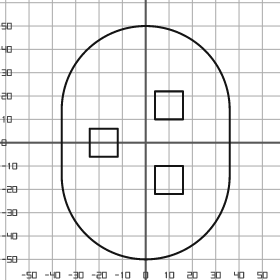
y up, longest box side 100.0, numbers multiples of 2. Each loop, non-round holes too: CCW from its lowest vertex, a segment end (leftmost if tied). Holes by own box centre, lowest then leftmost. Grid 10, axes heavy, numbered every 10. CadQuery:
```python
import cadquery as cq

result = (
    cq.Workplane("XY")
    .moveTo(-36.0, -14.0)
    .threePointArc((0.0, -50.0), (36.0, -14.0))
    .lineTo(36.0, 14.0)
    .threePointArc((0.0, 50.0), (-36.0, 14.0))
    .close()
    .moveTo(4.0, -22.0)
    .lineTo(16.0, -22.0)
    .lineTo(16.0, -10.0)
    .lineTo(4.0, -10.0)
    .close()
    .moveTo(-24.0, -6.0)
    .lineTo(-12.0, -6.0)
    .lineTo(-12.0, 6.0)
    .lineTo(-24.0, 6.0)
    .close()
    .moveTo(4.0, 10.0)
    .lineTo(16.0, 10.0)
    .lineTo(16.0, 22.0)
    .lineTo(4.0, 22.0)
    .close()
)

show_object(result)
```